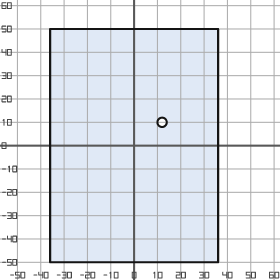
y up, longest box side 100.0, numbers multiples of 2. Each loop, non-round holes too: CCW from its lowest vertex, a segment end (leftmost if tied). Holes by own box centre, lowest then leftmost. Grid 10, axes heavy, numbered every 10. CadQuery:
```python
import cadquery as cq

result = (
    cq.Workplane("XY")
    .moveTo(-36.0, -50.0)
    .lineTo(36.0, -50.0)
    .lineTo(36.0, 50.0)
    .lineTo(-36.0, 50.0)
    .close()
    .moveTo(12.0, 10.0)
    .circle(2.0)
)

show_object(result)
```